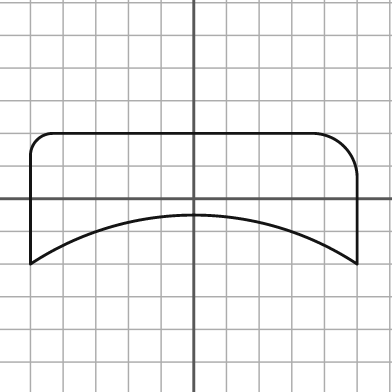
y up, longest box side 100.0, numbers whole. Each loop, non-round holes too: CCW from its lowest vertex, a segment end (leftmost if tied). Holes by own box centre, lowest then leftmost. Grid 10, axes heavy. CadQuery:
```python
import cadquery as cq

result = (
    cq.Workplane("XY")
    .moveTo(-50.0, -20.0)
    .threePointArc((0.0, -5.0), (50.0, -20.0))
    .lineTo(50.0, 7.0)
    .threePointArc((46.0, 16.0), (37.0, 20.0))
    .lineTo(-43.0, 20.0)
    .threePointArc((-48.0, 18.0), (-50.0, 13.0))
    .close()
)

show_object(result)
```